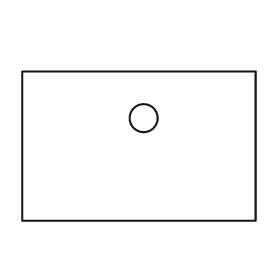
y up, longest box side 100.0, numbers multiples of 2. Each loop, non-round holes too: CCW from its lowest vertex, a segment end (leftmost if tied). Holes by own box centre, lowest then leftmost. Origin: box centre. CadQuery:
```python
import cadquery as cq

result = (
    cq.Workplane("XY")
    .moveTo(-50.0, -32.0)
    .lineTo(50.0, -32.0)
    .lineTo(50.0, 32.0)
    .lineTo(-50.0, 32.0)
    .close()
    .moveTo(2.0, 12.0)
    .circle(6.0)
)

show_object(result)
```